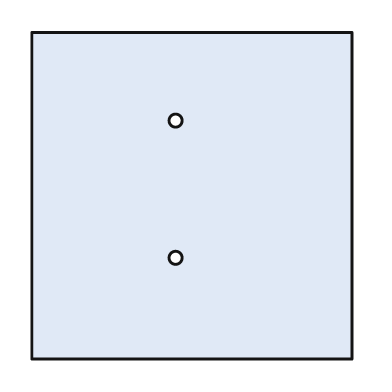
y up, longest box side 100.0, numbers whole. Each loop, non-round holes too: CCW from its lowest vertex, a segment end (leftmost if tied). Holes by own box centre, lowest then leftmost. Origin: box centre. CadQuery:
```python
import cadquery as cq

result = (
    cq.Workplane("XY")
    .moveTo(-49.0, -50.0)
    .lineTo(49.0, -50.0)
    .lineTo(49.0, 50.0)
    .lineTo(-49.0, 50.0)
    .close()
    .moveTo(-5.0, -19.0)
    .circle(2.0)
    .moveTo(-5.0, 23.0)
    .circle(2.0)
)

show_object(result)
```